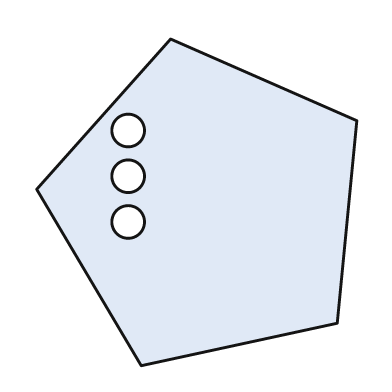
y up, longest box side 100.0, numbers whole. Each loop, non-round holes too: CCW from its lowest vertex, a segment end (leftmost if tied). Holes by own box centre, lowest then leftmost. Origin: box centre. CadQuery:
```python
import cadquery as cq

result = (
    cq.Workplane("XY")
    .moveTo(-17.0, -50.0)
    .lineTo(43.0, -37.0)
    .lineTo(49.0, 25.0)
    .lineTo(-8.0, 50.0)
    .lineTo(-49.0, 4.0)
    .close()
    .moveTo(-21.0, -6.0)
    .circle(5.0)
    .moveTo(-21.0, 8.0)
    .circle(5.0)
    .moveTo(-21.0, 22.0)
    .circle(5.0)
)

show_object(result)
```